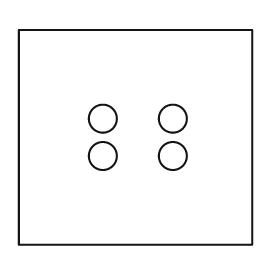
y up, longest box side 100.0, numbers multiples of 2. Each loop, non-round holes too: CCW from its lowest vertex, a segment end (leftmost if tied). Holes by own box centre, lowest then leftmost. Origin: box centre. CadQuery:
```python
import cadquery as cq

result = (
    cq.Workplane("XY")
    .moveTo(-50.0, -46.0)
    .lineTo(50.0, -46.0)
    .lineTo(50.0, 46.0)
    .lineTo(-50.0, 46.0)
    .close()
    .moveTo(-14.0, -8.0)
    .circle(6.0)
    .moveTo(16.0, -8.0)
    .circle(6.0)
    .moveTo(-14.0, 8.0)
    .circle(6.0)
    .moveTo(16.0, 8.0)
    .circle(6.0)
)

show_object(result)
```